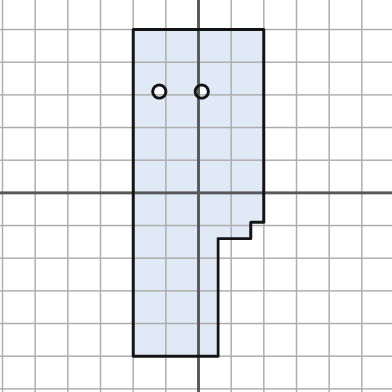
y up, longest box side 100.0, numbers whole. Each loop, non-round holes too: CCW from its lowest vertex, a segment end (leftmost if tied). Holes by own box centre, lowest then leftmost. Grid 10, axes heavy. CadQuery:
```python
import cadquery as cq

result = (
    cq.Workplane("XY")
    .moveTo(-20.0, -50.0)
    .lineTo(6.0, -50.0)
    .lineTo(6.0, -14.0)
    .lineTo(16.0, -14.0)
    .lineTo(16.0, -9.0)
    .lineTo(20.0, -9.0)
    .lineTo(20.0, 50.0)
    .lineTo(-20.0, 50.0)
    .close()
    .moveTo(-12.0, 31.0)
    .circle(2.0)
    .moveTo(1.0, 31.0)
    .circle(2.0)
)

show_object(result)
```